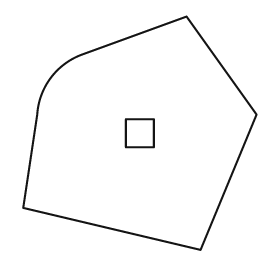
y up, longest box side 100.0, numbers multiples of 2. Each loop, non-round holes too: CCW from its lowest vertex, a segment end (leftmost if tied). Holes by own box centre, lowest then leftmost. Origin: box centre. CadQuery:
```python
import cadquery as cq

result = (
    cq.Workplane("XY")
    .moveTo(26.0, -50.0)
    .lineTo(50.0, 8.0)
    .lineTo(20.0, 50.0)
    .lineTo(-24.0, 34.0)
    .threePointArc((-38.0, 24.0), (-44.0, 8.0))
    .lineTo(-50.0, -32.0)
    .close()
    .moveTo(-6.0, -6.0)
    .lineTo(6.0, -6.0)
    .lineTo(6.0, 6.0)
    .lineTo(-6.0, 6.0)
    .close()
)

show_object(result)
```